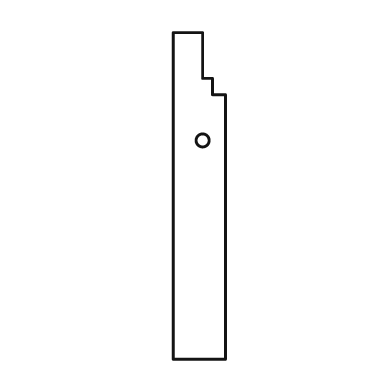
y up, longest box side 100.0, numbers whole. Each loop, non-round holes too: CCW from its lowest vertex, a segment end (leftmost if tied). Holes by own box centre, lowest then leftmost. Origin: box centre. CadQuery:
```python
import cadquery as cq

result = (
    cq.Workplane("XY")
    .moveTo(-8.0, -50.0)
    .lineTo(8.0, -50.0)
    .lineTo(8.0, 31.0)
    .lineTo(4.0, 31.0)
    .lineTo(4.0, 36.0)
    .lineTo(1.0, 36.0)
    .lineTo(1.0, 50.0)
    .lineTo(-8.0, 50.0)
    .close()
    .moveTo(1.0, 17.0)
    .circle(2.0)
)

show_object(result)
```